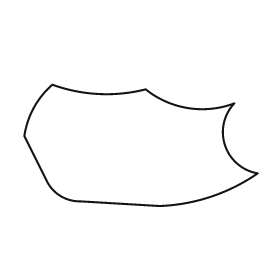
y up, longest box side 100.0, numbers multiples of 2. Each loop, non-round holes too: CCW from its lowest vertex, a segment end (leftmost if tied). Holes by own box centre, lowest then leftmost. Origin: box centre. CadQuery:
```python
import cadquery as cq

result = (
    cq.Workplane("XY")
    .moveTo(8.0, -26.0)
    .threePointArc((30.0, -22.0), (50.0, -12.0))
    .threePointArc((36.0, 0.0), (40.0, 18.0))
    .threePointArc((20.0, 16.0), (2.0, 24.0))
    .threePointArc((-18.0, 22.0), (-38.0, 26.0))
    .threePointArc((-46.0, 16.0), (-50.0, 4.0))
    .lineTo(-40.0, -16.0)
    .threePointArc((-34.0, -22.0), (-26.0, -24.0))
    .close()
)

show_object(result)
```